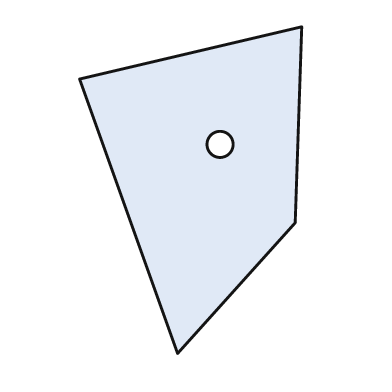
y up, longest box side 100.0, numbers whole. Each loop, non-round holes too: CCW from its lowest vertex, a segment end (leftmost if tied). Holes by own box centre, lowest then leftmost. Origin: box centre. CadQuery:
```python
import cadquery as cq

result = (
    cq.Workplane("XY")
    .moveTo(-4.0, -50.0)
    .lineTo(32.0, -10.0)
    .lineTo(34.0, 50.0)
    .lineTo(-34.0, 34.0)
    .close()
    .moveTo(9.0, 14.0)
    .circle(4.0)
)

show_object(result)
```